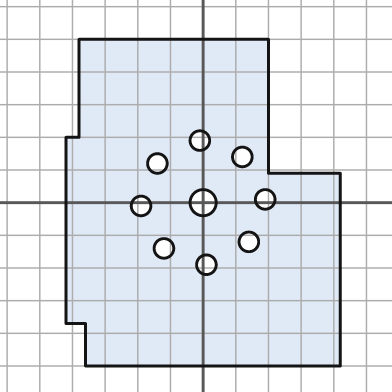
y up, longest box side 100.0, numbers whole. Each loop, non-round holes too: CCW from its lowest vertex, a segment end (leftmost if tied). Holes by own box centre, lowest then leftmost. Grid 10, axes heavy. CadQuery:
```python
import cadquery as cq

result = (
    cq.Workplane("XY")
    .moveTo(-36.0, -50.0)
    .lineTo(42.0, -50.0)
    .lineTo(42.0, 9.0)
    .lineTo(20.0, 9.0)
    .lineTo(20.0, 50.0)
    .lineTo(-38.0, 50.0)
    .lineTo(-38.0, 20.0)
    .lineTo(-42.0, 20.0)
    .lineTo(-42.0, -37.0)
    .lineTo(-36.0, -37.0)
    .close()
    .moveTo(1.0, -19.0)
    .circle(3.0)
    .moveTo(-12.0, -14.0)
    .circle(3.0)
    .moveTo(14.0, -12.0)
    .circle(3.0)
    .moveTo(-19.0, -1.0)
    .circle(3.0)
    .moveTo(0.0, 0.0)
    .circle(4.0)
    .moveTo(19.0, 1.0)
    .circle(3.0)
    .moveTo(-14.0, 12.0)
    .circle(3.0)
    .moveTo(12.0, 14.0)
    .circle(3.0)
    .moveTo(-1.0, 19.0)
    .circle(3.0)
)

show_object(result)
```